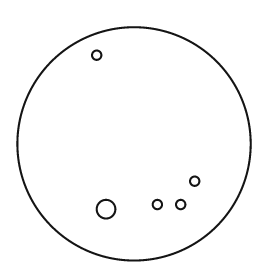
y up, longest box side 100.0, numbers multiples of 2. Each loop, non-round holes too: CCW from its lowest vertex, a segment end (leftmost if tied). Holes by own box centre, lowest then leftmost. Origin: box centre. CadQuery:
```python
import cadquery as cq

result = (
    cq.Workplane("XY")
    .moveTo(0.0, 0.0)
    .circle(50.0)
    .moveTo(-12.0, -28.0)
    .circle(4.0)
    .moveTo(10.0, -26.0)
    .circle(2.0)
    .moveTo(20.0, -26.0)
    .circle(2.0)
    .moveTo(26.0, -16.0)
    .circle(2.0)
    .moveTo(-16.0, 38.0)
    .circle(2.0)
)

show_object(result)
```